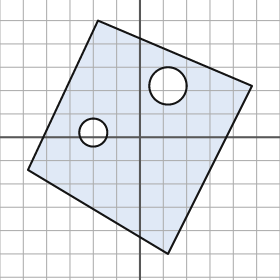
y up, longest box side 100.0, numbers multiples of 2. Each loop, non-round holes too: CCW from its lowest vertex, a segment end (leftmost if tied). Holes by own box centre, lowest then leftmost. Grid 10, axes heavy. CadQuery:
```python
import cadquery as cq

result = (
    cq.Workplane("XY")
    .moveTo(12.0, -50.0)
    .lineTo(48.0, 22.0)
    .lineTo(-18.0, 50.0)
    .lineTo(-48.0, -14.0)
    .close()
    .moveTo(-20.0, 2.0)
    .circle(6.0)
    .moveTo(12.0, 22.0)
    .circle(8.0)
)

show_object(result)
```